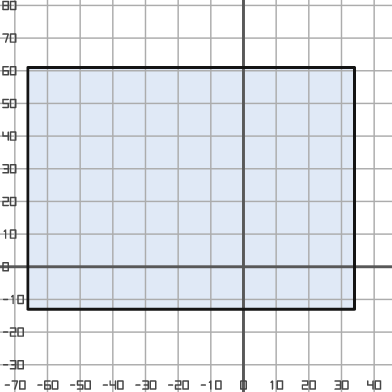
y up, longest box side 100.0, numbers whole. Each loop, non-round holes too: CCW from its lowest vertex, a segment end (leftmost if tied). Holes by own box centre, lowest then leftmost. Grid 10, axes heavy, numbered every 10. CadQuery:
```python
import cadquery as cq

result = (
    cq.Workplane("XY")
    .moveTo(-66.0, -13.0)
    .lineTo(34.0, -13.0)
    .lineTo(34.0, 61.0)
    .lineTo(-66.0, 61.0)
    .close()
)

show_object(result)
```